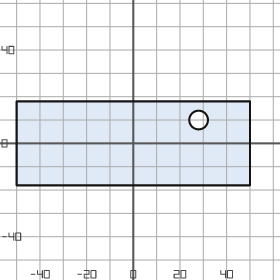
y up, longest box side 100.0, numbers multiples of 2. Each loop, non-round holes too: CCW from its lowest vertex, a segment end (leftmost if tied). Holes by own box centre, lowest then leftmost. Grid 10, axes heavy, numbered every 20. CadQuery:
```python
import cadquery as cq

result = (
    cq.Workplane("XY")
    .moveTo(-50.0, -18.0)
    .lineTo(50.0, -18.0)
    .lineTo(50.0, 18.0)
    .lineTo(-50.0, 18.0)
    .close()
    .moveTo(28.0, 10.0)
    .circle(4.0)
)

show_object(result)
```